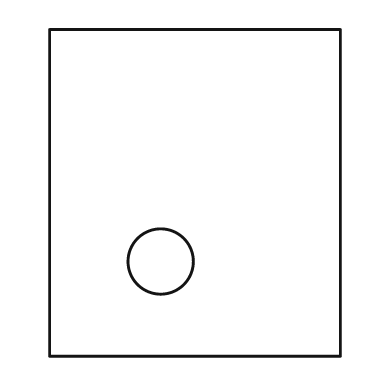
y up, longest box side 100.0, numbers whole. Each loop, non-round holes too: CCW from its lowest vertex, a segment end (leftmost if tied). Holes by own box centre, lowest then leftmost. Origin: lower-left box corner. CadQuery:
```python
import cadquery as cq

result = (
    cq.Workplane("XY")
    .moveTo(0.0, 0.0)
    .lineTo(89.0, 0.0)
    .lineTo(89.0, 100.0)
    .lineTo(0.0, 100.0)
    .close()
    .moveTo(34.0, 29.0)
    .circle(10.0)
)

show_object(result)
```